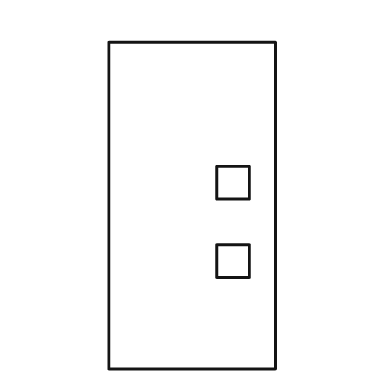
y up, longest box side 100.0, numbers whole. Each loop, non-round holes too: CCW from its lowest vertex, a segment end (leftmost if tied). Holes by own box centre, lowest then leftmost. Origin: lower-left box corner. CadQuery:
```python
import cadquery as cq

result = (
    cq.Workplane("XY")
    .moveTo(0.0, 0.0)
    .lineTo(51.0, 0.0)
    .lineTo(51.0, 100.0)
    .lineTo(0.0, 100.0)
    .close()
    .moveTo(33.0, 28.0)
    .lineTo(43.0, 28.0)
    .lineTo(43.0, 38.0)
    .lineTo(33.0, 38.0)
    .close()
    .moveTo(33.0, 52.0)
    .lineTo(43.0, 52.0)
    .lineTo(43.0, 62.0)
    .lineTo(33.0, 62.0)
    .close()
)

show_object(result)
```